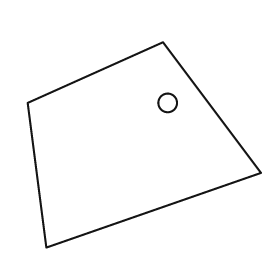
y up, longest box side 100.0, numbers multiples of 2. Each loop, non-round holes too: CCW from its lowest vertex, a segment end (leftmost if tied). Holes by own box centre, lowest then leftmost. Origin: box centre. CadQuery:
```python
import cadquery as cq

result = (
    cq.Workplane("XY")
    .moveTo(-42.0, -44.0)
    .lineTo(50.0, -12.0)
    .lineTo(8.0, 44.0)
    .lineTo(-50.0, 18.0)
    .close()
    .moveTo(10.0, 18.0)
    .circle(4.0)
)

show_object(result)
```